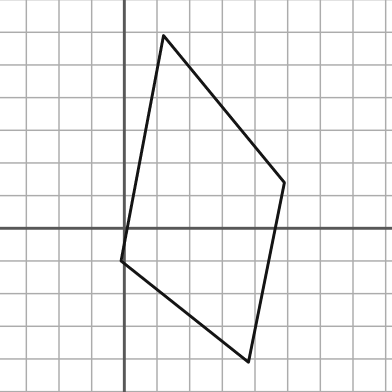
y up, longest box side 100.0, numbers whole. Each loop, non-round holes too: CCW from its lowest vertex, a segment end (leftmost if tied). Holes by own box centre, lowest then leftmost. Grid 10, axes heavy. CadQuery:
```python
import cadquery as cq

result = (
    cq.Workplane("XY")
    .moveTo(38.0, -41.0)
    .lineTo(49.0, 14.0)
    .lineTo(12.0, 59.0)
    .lineTo(-1.0, -10.0)
    .close()
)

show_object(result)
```